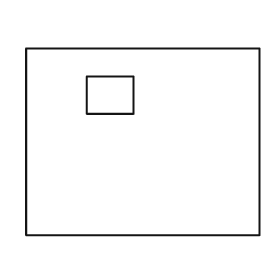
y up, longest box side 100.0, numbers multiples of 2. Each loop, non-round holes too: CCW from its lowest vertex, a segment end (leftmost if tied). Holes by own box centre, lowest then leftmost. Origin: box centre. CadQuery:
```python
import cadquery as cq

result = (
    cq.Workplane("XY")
    .moveTo(-50.0, -40.0)
    .lineTo(50.0, -40.0)
    .lineTo(50.0, 40.0)
    .lineTo(-50.0, 40.0)
    .close()
    .moveTo(-24.0, 12.0)
    .lineTo(-4.0, 12.0)
    .lineTo(-4.0, 28.0)
    .lineTo(-24.0, 28.0)
    .close()
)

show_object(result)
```